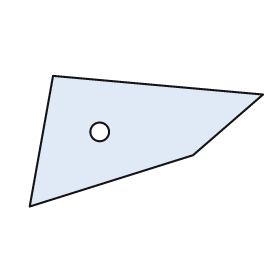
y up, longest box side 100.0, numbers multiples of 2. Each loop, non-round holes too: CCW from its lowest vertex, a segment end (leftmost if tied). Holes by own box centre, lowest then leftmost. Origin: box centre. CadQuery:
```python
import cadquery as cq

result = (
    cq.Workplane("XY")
    .moveTo(-50.0, -28.0)
    .lineTo(20.0, -6.0)
    .lineTo(50.0, 20.0)
    .lineTo(-40.0, 28.0)
    .close()
    .moveTo(-20.0, 4.0)
    .circle(4.0)
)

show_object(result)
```